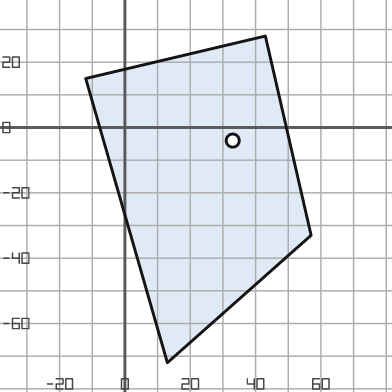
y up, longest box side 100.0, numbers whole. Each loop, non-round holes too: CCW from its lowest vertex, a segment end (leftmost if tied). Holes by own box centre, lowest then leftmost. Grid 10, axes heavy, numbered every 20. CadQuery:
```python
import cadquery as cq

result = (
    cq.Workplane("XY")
    .moveTo(13.0, -72.0)
    .lineTo(57.0, -33.0)
    .lineTo(43.0, 28.0)
    .lineTo(-12.0, 15.0)
    .close()
    .moveTo(33.0, -4.0)
    .circle(2.0)
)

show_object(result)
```